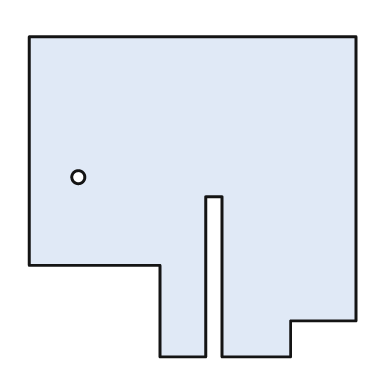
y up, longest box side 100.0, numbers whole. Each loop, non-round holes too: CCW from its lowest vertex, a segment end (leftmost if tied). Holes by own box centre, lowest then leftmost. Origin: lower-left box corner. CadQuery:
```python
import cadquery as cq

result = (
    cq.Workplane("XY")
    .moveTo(40.0, 0.0)
    .lineTo(54.0, 0.0)
    .lineTo(54.0, 49.0)
    .lineTo(59.0, 49.0)
    .lineTo(59.0, 0.0)
    .lineTo(80.0, 0.0)
    .lineTo(80.0, 11.0)
    .lineTo(100.0, 11.0)
    .lineTo(100.0, 98.0)
    .lineTo(0.0, 98.0)
    .lineTo(0.0, 28.0)
    .lineTo(40.0, 28.0)
    .close()
    .moveTo(15.0, 55.0)
    .circle(2.0)
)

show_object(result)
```